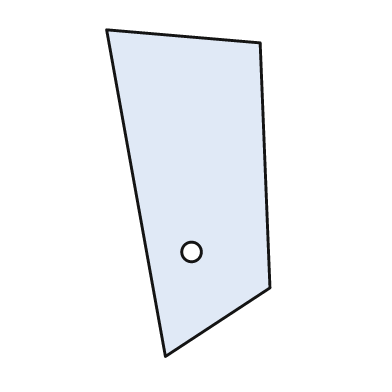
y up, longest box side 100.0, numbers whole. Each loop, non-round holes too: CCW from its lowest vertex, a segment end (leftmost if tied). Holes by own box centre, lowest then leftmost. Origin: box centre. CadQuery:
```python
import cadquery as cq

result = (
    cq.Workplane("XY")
    .moveTo(-7.0, -50.0)
    .lineTo(25.0, -29.0)
    .lineTo(22.0, 46.0)
    .lineTo(-25.0, 50.0)
    .close()
    .moveTo(1.0, -18.0)
    .circle(3.0)
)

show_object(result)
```